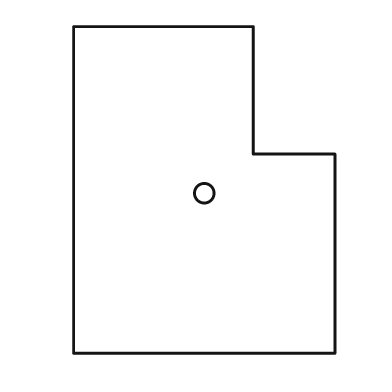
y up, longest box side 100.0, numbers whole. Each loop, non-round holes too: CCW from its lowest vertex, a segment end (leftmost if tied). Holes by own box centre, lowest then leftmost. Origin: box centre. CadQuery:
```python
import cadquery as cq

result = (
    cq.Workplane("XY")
    .moveTo(-40.0, -50.0)
    .lineTo(40.0, -50.0)
    .lineTo(40.0, 11.0)
    .lineTo(15.0, 11.0)
    .lineTo(15.0, 50.0)
    .lineTo(-40.0, 50.0)
    .close()
    .moveTo(0.0, -1.0)
    .circle(3.0)
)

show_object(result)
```